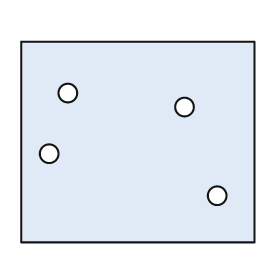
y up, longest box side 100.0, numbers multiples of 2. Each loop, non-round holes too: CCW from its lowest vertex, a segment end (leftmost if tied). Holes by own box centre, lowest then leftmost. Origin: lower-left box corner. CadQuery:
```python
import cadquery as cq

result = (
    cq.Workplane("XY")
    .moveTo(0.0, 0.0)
    .lineTo(100.0, 0.0)
    .lineTo(100.0, 86.0)
    .lineTo(0.0, 86.0)
    .close()
    .moveTo(84.0, 20.0)
    .circle(4.0)
    .moveTo(12.0, 38.0)
    .circle(4.0)
    .moveTo(70.0, 58.0)
    .circle(4.0)
    .moveTo(20.0, 64.0)
    .circle(4.0)
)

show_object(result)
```